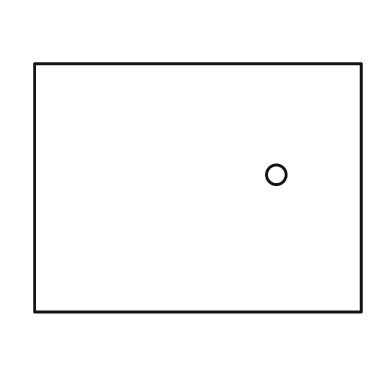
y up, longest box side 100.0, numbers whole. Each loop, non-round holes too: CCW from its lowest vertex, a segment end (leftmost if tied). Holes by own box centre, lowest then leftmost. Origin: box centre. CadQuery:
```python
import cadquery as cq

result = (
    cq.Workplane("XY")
    .moveTo(-50.0, -38.0)
    .lineTo(50.0, -38.0)
    .lineTo(50.0, 38.0)
    .lineTo(-50.0, 38.0)
    .close()
    .moveTo(24.0, 4.0)
    .circle(3.0)
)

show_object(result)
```